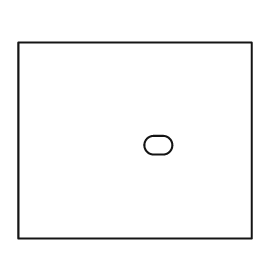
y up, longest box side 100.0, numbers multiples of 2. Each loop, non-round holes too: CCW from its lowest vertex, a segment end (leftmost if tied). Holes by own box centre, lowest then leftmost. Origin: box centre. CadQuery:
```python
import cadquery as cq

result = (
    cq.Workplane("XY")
    .moveTo(-50.0, -42.0)
    .lineTo(50.0, -42.0)
    .lineTo(50.0, 42.0)
    .lineTo(-50.0, 42.0)
    .close()
    .moveTo(8.0, -6.0)
    .lineTo(12.0, -6.0)
    .threePointArc((16.0, -2.0), (12.0, 2.0))
    .lineTo(8.0, 2.0)
    .threePointArc((4.0, -2.0), (8.0, -6.0))
    .close()
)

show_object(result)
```